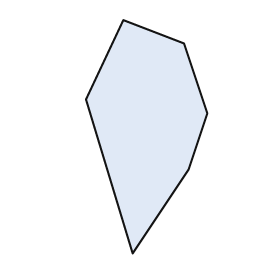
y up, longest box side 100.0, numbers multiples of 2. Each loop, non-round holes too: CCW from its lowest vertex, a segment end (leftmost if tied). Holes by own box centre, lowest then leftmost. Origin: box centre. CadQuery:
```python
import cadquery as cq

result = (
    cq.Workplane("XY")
    .moveTo(-6.0, -50.0)
    .lineTo(18.0, -14.0)
    .lineTo(26.0, 10.0)
    .lineTo(16.0, 40.0)
    .lineTo(-10.0, 50.0)
    .lineTo(-26.0, 16.0)
    .close()
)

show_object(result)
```